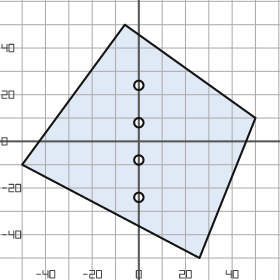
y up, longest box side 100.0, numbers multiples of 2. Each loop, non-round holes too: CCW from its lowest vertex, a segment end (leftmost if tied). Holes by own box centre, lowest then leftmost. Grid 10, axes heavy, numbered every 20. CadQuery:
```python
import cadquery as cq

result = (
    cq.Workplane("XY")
    .moveTo(26.0, -50.0)
    .lineTo(50.0, 10.0)
    .lineTo(-6.0, 50.0)
    .lineTo(-50.0, -10.0)
    .close()
    .moveTo(0.0, -24.0)
    .circle(2.0)
    .moveTo(0.0, -8.0)
    .circle(2.0)
    .moveTo(0.0, 8.0)
    .circle(2.0)
    .moveTo(0.0, 24.0)
    .circle(2.0)
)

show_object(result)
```